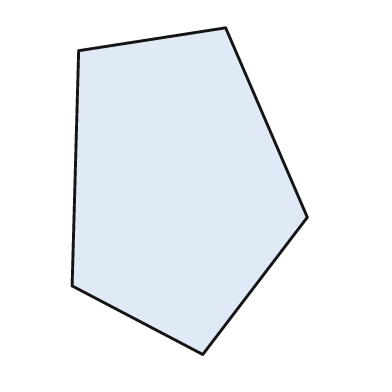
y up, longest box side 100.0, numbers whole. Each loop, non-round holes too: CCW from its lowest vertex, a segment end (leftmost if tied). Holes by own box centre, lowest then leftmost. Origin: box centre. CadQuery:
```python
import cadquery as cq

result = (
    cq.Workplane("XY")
    .moveTo(4.0, -50.0)
    .lineTo(36.0, -8.0)
    .lineTo(11.0, 50.0)
    .lineTo(-34.0, 43.0)
    .lineTo(-36.0, -29.0)
    .close()
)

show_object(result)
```